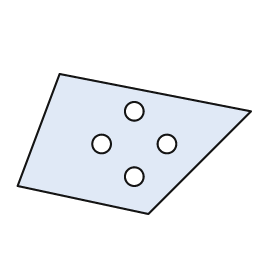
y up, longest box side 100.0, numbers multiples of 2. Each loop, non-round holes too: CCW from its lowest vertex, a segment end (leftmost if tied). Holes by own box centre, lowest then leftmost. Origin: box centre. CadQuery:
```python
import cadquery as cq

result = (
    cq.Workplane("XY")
    .moveTo(6.0, -30.0)
    .lineTo(50.0, 14.0)
    .lineTo(-32.0, 30.0)
    .lineTo(-50.0, -18.0)
    .close()
    .moveTo(0.0, -14.0)
    .circle(4.0)
    .moveTo(-14.0, 0.0)
    .circle(4.0)
    .moveTo(14.0, 0.0)
    .circle(4.0)
    .moveTo(0.0, 14.0)
    .circle(4.0)
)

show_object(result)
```